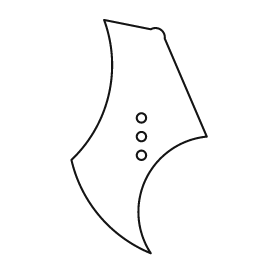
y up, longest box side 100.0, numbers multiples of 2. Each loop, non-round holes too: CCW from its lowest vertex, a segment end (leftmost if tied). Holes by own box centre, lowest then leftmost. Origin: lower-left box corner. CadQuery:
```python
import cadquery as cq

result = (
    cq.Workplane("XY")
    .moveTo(34.0, 0.0)
    .threePointArc((32.0, 32.0), (58.0, 50.0))
    .lineTo(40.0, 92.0)
    .threePointArc((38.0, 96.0), (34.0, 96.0))
    .lineTo(14.0, 100.0)
    .threePointArc((16.0, 68.0), (0.0, 40.0))
    .threePointArc((12.0, 16.0), (34.0, 0.0))
    .close()
    .moveTo(30.0, 42.0)
    .circle(2.0)
    .moveTo(30.0, 50.0)
    .circle(2.0)
    .moveTo(30.0, 58.0)
    .circle(2.0)
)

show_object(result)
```